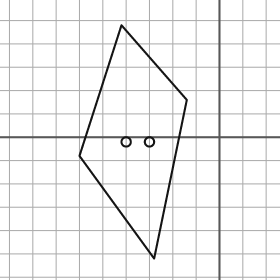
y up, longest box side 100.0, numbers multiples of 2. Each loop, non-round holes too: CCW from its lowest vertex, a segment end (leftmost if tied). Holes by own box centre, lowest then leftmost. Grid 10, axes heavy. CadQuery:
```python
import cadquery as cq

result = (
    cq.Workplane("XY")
    .moveTo(-28.0, -52.0)
    .lineTo(-14.0, 16.0)
    .lineTo(-42.0, 48.0)
    .lineTo(-60.0, -8.0)
    .close()
    .moveTo(-40.0, -2.0)
    .circle(2.0)
    .moveTo(-30.0, -2.0)
    .circle(2.0)
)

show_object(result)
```